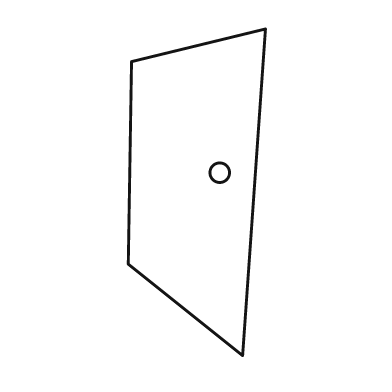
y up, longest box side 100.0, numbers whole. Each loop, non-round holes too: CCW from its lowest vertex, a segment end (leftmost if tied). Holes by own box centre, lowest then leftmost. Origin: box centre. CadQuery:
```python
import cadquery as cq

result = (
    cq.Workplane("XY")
    .moveTo(14.0, -50.0)
    .lineTo(21.0, 50.0)
    .lineTo(-20.0, 40.0)
    .lineTo(-21.0, -22.0)
    .close()
    .moveTo(7.0, 6.0)
    .circle(3.0)
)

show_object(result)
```